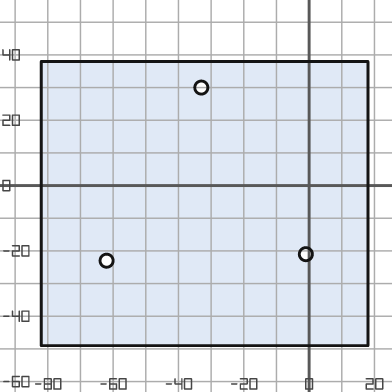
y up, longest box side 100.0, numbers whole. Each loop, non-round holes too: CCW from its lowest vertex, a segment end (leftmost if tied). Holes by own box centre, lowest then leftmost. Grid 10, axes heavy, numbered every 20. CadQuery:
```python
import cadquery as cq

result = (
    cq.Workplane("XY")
    .moveTo(-82.0, -49.0)
    .lineTo(18.0, -49.0)
    .lineTo(18.0, 38.0)
    .lineTo(-82.0, 38.0)
    .close()
    .moveTo(-62.0, -23.0)
    .circle(2.0)
    .moveTo(-1.0, -21.0)
    .circle(2.0)
    .moveTo(-33.0, 30.0)
    .circle(2.0)
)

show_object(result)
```